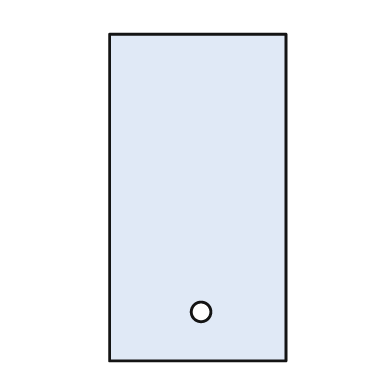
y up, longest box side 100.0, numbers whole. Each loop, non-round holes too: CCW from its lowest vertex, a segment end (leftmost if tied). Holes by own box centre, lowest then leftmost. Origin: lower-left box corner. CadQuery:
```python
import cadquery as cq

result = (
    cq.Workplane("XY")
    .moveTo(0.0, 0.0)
    .lineTo(54.0, 0.0)
    .lineTo(54.0, 100.0)
    .lineTo(0.0, 100.0)
    .close()
    .moveTo(28.0, 15.0)
    .circle(3.0)
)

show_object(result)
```